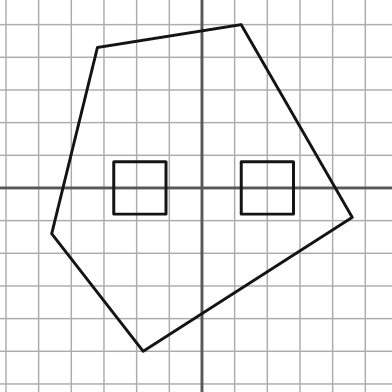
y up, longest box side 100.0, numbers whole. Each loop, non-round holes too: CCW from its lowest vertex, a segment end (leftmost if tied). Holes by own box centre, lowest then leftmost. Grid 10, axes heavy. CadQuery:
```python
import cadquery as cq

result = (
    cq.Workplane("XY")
    .moveTo(-18.0, -50.0)
    .lineTo(46.0, -9.0)
    .lineTo(12.0, 50.0)
    .lineTo(-32.0, 43.0)
    .lineTo(-46.0, -14.0)
    .close()
    .moveTo(-27.0, -8.0)
    .lineTo(-11.0, -8.0)
    .lineTo(-11.0, 8.0)
    .lineTo(-27.0, 8.0)
    .close()
    .moveTo(12.0, -8.0)
    .lineTo(28.0, -8.0)
    .lineTo(28.0, 8.0)
    .lineTo(12.0, 8.0)
    .close()
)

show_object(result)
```